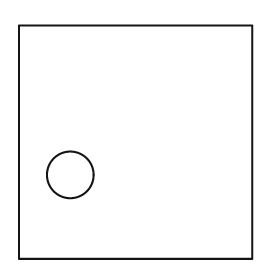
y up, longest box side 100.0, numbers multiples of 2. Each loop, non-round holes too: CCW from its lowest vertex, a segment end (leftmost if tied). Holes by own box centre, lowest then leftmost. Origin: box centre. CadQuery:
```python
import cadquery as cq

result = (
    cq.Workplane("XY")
    .moveTo(-50.0, -50.0)
    .lineTo(50.0, -50.0)
    .lineTo(50.0, 50.0)
    .lineTo(-50.0, 50.0)
    .close()
    .moveTo(-28.0, -14.0)
    .circle(10.0)
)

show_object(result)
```